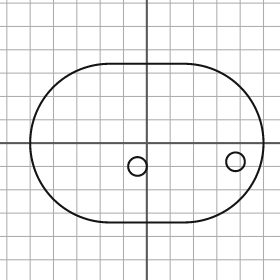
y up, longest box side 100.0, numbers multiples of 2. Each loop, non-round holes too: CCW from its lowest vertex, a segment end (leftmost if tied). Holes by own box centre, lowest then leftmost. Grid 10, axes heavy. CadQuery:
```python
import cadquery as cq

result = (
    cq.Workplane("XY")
    .moveTo(-16.0, -34.0)
    .lineTo(16.0, -34.0)
    .threePointArc((50.0, 0.0), (16.0, 34.0))
    .lineTo(-16.0, 34.0)
    .threePointArc((-50.0, 0.0), (-16.0, -34.0))
    .close()
    .moveTo(-4.0, -10.0)
    .circle(4.0)
    .moveTo(38.0, -8.0)
    .circle(4.0)
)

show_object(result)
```